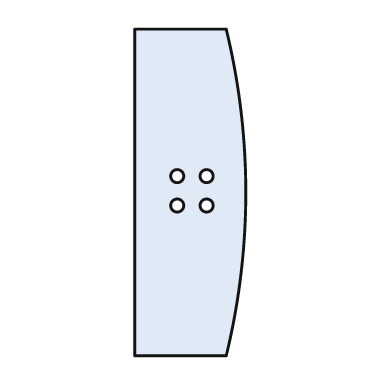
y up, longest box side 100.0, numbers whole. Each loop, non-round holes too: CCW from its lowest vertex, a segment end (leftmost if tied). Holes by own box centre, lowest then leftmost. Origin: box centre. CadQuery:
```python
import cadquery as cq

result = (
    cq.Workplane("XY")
    .moveTo(-17.0, -50.0)
    .lineTo(11.0, -50.0)
    .threePointArc((17.0, 0.0), (11.0, 50.0))
    .lineTo(-17.0, 50.0)
    .close()
    .moveTo(-4.0, -4.0)
    .circle(2.0)
    .moveTo(5.0, -4.0)
    .circle(2.0)
    .moveTo(-4.0, 5.0)
    .circle(2.0)
    .moveTo(5.0, 5.0)
    .circle(2.0)
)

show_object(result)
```